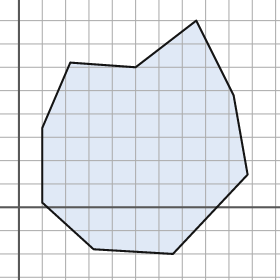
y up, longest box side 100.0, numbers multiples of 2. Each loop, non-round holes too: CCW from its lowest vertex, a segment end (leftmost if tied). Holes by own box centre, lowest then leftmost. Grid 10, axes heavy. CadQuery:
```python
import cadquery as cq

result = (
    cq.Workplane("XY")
    .moveTo(66.0, -20.0)
    .lineTo(98.0, 14.0)
    .lineTo(92.0, 48.0)
    .lineTo(76.0, 80.0)
    .lineTo(50.0, 60.0)
    .lineTo(22.0, 62.0)
    .lineTo(10.0, 34.0)
    .lineTo(10.0, 2.0)
    .lineTo(32.0, -18.0)
    .close()
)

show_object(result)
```